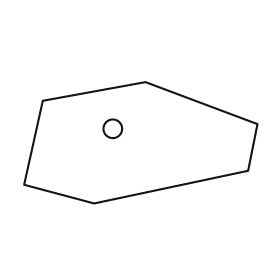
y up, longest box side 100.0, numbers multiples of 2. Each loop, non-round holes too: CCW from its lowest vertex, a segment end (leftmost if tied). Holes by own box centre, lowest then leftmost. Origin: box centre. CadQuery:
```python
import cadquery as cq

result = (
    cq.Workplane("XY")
    .moveTo(-20.0, -26.0)
    .lineTo(46.0, -12.0)
    .lineTo(50.0, 8.0)
    .lineTo(2.0, 26.0)
    .lineTo(-42.0, 18.0)
    .lineTo(-50.0, -18.0)
    .close()
    .moveTo(-12.0, 6.0)
    .circle(4.0)
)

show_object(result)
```